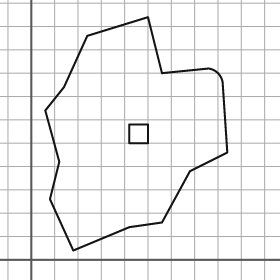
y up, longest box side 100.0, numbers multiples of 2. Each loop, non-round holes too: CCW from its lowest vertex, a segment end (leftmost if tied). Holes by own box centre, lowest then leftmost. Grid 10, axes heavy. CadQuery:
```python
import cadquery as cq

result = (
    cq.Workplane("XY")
    .moveTo(18.0, 4.0)
    .lineTo(42.0, 14.0)
    .lineTo(56.0, 16.0)
    .lineTo(68.0, 38.0)
    .lineTo(84.0, 46.0)
    .lineTo(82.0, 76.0)
    .threePointArc((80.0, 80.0), (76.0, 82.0))
    .lineTo(56.0, 80.0)
    .lineTo(50.0, 104.0)
    .lineTo(24.0, 96.0)
    .lineTo(14.0, 74.0)
    .lineTo(6.0, 64.0)
    .lineTo(12.0, 42.0)
    .lineTo(8.0, 26.0)
    .close()
    .moveTo(42.0, 50.0)
    .lineTo(50.0, 50.0)
    .lineTo(50.0, 58.0)
    .lineTo(42.0, 58.0)
    .close()
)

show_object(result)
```